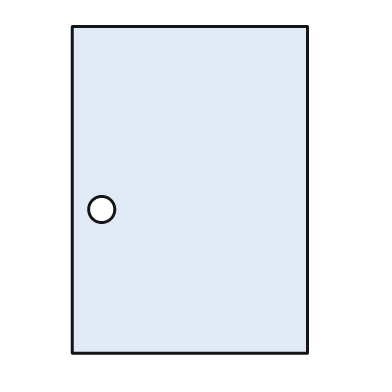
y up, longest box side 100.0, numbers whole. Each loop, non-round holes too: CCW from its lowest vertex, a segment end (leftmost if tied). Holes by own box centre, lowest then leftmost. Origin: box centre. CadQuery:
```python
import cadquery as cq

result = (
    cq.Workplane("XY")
    .moveTo(-36.0, -50.0)
    .lineTo(36.0, -50.0)
    .lineTo(36.0, 50.0)
    .lineTo(-36.0, 50.0)
    .close()
    .moveTo(-27.0, -6.0)
    .circle(4.0)
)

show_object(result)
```